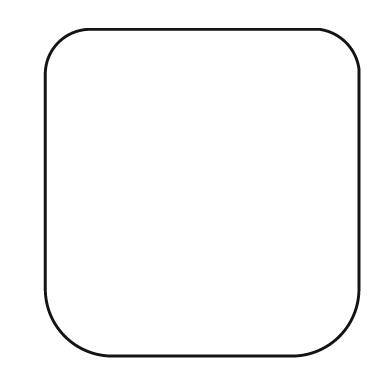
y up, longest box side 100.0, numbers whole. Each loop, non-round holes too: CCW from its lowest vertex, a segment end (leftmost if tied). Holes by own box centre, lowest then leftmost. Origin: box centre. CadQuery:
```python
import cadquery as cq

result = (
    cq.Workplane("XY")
    .moveTo(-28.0, -50.0)
    .lineTo(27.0, -50.0)
    .threePointArc((42.0, -44.0), (48.0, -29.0))
    .lineTo(48.0, 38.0)
    .threePointArc((44.0, 46.0), (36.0, 50.0))
    .lineTo(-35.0, 50.0)
    .threePointArc((-44.0, 46.0), (-48.0, 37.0))
    .lineTo(-48.0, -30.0)
    .threePointArc((-42.0, -44.0), (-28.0, -50.0))
    .close()
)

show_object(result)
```